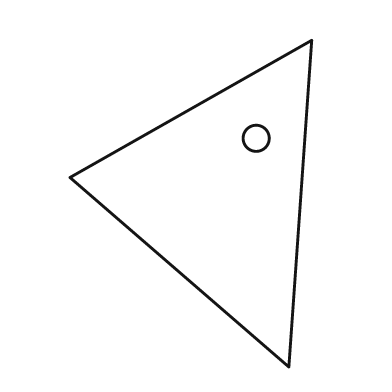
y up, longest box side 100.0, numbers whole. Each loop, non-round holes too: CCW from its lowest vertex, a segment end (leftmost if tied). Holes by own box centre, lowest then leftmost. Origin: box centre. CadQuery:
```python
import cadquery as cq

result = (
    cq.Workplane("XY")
    .moveTo(30.0, -50.0)
    .lineTo(37.0, 50.0)
    .lineTo(-37.0, 8.0)
    .close()
    .moveTo(20.0, 20.0)
    .circle(4.0)
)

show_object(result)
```